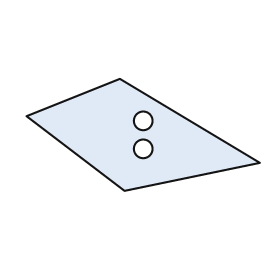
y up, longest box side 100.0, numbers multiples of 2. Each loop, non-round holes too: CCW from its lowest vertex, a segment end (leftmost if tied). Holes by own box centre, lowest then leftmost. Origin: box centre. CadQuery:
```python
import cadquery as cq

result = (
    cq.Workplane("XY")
    .moveTo(-8.0, -24.0)
    .lineTo(50.0, -12.0)
    .lineTo(-10.0, 24.0)
    .lineTo(-50.0, 8.0)
    .close()
    .moveTo(0.0, -6.0)
    .circle(4.0)
    .moveTo(0.0, 6.0)
    .circle(4.0)
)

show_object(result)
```